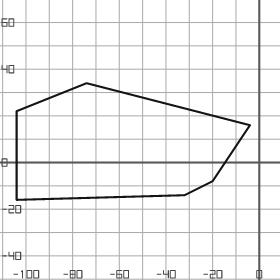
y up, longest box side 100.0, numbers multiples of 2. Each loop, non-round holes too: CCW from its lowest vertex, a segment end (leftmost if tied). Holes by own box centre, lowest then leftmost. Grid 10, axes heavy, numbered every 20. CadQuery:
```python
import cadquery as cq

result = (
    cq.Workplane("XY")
    .moveTo(-104.0, -16.0)
    .lineTo(-32.0, -14.0)
    .lineTo(-20.0, -8.0)
    .lineTo(-4.0, 16.0)
    .lineTo(-74.0, 34.0)
    .lineTo(-104.0, 22.0)
    .close()
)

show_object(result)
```